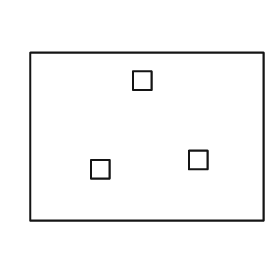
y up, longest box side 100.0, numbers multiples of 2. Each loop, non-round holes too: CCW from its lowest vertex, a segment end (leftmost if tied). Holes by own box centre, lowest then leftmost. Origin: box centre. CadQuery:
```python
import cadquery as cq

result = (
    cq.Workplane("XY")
    .moveTo(-50.0, -36.0)
    .lineTo(50.0, -36.0)
    .lineTo(50.0, 36.0)
    .lineTo(-50.0, 36.0)
    .close()
    .moveTo(-24.0, -18.0)
    .lineTo(-16.0, -18.0)
    .lineTo(-16.0, -10.0)
    .lineTo(-24.0, -10.0)
    .close()
    .moveTo(18.0, -14.0)
    .lineTo(26.0, -14.0)
    .lineTo(26.0, -6.0)
    .lineTo(18.0, -6.0)
    .close()
    .moveTo(-6.0, 20.0)
    .lineTo(2.0, 20.0)
    .lineTo(2.0, 28.0)
    .lineTo(-6.0, 28.0)
    .close()
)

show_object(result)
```